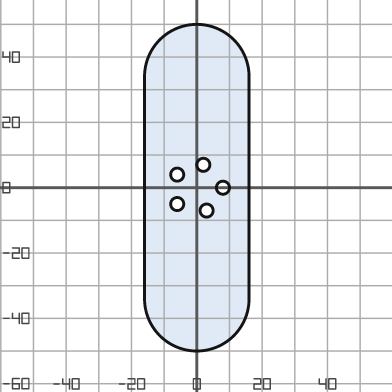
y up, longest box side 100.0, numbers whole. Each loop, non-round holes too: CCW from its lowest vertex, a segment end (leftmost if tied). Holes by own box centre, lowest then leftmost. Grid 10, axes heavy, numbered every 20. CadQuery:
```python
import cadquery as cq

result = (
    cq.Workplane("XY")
    .moveTo(-16.0, -34.0)
    .threePointArc((0.0, -50.0), (16.0, -34.0))
    .lineTo(16.0, 34.0)
    .threePointArc((0.0, 50.0), (-16.0, 34.0))
    .close()
    .moveTo(3.0, -7.0)
    .circle(2.0)
    .moveTo(-6.0, -5.0)
    .circle(2.0)
    .moveTo(8.0, 0.0)
    .circle(2.0)
    .moveTo(-6.0, 4.0)
    .circle(2.0)
    .moveTo(2.0, 7.0)
    .circle(2.0)
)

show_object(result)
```